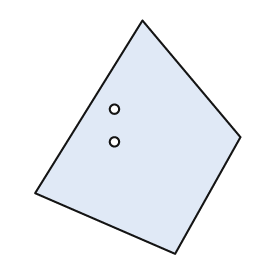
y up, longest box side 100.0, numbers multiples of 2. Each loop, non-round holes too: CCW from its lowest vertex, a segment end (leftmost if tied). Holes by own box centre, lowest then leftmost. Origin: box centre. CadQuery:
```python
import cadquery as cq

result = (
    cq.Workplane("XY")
    .moveTo(16.0, -50.0)
    .lineTo(44.0, 0.0)
    .lineTo(2.0, 50.0)
    .lineTo(-44.0, -24.0)
    .close()
    .moveTo(-10.0, -2.0)
    .circle(2.0)
    .moveTo(-10.0, 12.0)
    .circle(2.0)
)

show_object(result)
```